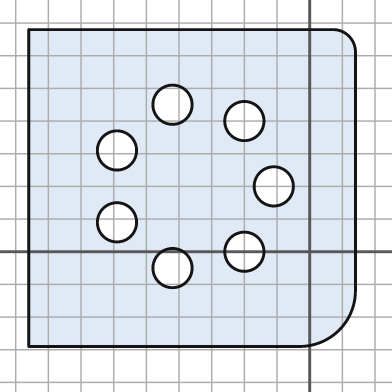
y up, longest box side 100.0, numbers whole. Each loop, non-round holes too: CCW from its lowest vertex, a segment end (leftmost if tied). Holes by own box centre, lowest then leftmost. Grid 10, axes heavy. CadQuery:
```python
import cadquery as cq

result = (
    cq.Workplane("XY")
    .moveTo(-86.0, -29.0)
    .lineTo(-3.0, -29.0)
    .threePointArc((9.0, -24.0), (14.0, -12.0))
    .lineTo(14.0, 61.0)
    .threePointArc((12.0, 66.0), (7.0, 68.0))
    .lineTo(-86.0, 68.0)
    .close()
    .moveTo(-42.0, -5.0)
    .circle(6.0)
    .moveTo(-20.0, 0.0)
    .circle(6.0)
    .moveTo(-59.0, 9.0)
    .circle(6.0)
    .moveTo(-11.0, 20.0)
    .circle(6.0)
    .moveTo(-59.0, 31.0)
    .circle(6.0)
    .moveTo(-20.0, 40.0)
    .circle(6.0)
    .moveTo(-42.0, 45.0)
    .circle(6.0)
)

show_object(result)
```